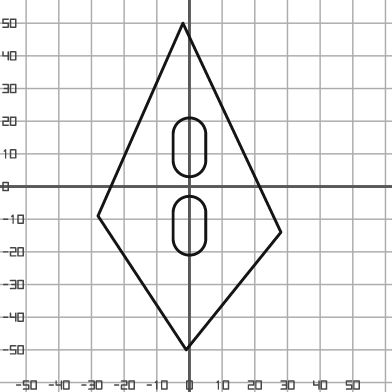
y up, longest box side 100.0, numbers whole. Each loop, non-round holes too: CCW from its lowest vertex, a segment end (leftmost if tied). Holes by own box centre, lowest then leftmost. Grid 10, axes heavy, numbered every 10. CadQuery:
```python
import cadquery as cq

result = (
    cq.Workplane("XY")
    .moveTo(-1.0, -50.0)
    .lineTo(28.0, -14.0)
    .lineTo(-2.0, 50.0)
    .lineTo(-28.0, -9.0)
    .close()
    .moveTo(-5.0, -16.0)
    .threePointArc((0.0, -21.0), (5.0, -16.0))
    .lineTo(5.0, -8.0)
    .threePointArc((0.0, -3.0), (-5.0, -8.0))
    .close()
    .moveTo(-5.0, 8.0)
    .threePointArc((0.0, 3.0), (5.0, 8.0))
    .lineTo(5.0, 16.0)
    .threePointArc((0.0, 21.0), (-5.0, 16.0))
    .close()
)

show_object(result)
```